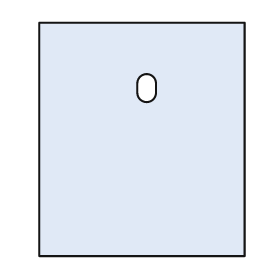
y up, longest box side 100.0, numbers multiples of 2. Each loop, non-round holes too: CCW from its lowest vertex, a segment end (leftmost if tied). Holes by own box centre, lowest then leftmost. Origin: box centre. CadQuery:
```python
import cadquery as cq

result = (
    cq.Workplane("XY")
    .moveTo(-44.0, -50.0)
    .lineTo(44.0, -50.0)
    .lineTo(44.0, 50.0)
    .lineTo(-44.0, 50.0)
    .close()
    .moveTo(-2.0, 20.0)
    .threePointArc((2.0, 16.0), (6.0, 20.0))
    .lineTo(6.0, 24.0)
    .threePointArc((2.0, 28.0), (-2.0, 24.0))
    .close()
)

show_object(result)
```